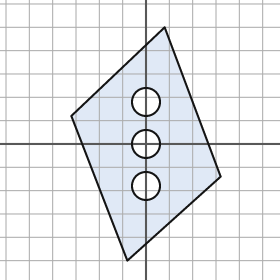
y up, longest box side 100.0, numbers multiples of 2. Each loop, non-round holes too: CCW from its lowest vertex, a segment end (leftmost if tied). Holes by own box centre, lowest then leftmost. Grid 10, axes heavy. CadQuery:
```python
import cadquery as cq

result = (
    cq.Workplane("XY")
    .moveTo(-8.0, -50.0)
    .lineTo(32.0, -14.0)
    .lineTo(8.0, 50.0)
    .lineTo(-32.0, 12.0)
    .close()
    .moveTo(0.0, -18.0)
    .circle(6.0)
    .moveTo(0.0, 0.0)
    .circle(6.0)
    .moveTo(0.0, 18.0)
    .circle(6.0)
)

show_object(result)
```